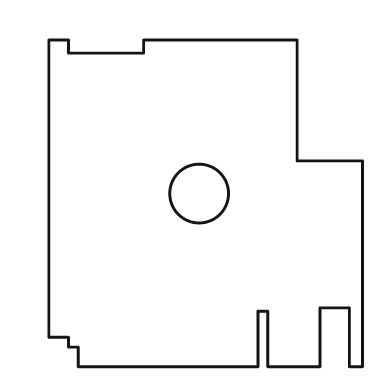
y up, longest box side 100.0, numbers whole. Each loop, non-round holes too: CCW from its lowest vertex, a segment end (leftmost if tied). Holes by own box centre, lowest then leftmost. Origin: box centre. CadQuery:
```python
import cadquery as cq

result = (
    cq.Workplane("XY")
    .moveTo(-39.0, -50.0)
    .lineTo(16.0, -50.0)
    .lineTo(16.0, -33.0)
    .lineTo(19.0, -33.0)
    .lineTo(19.0, -50.0)
    .lineTo(35.0, -50.0)
    .lineTo(35.0, -32.0)
    .lineTo(44.0, -32.0)
    .lineTo(44.0, -50.0)
    .lineTo(48.0, -50.0)
    .lineTo(48.0, 13.0)
    .lineTo(28.0, 13.0)
    .lineTo(28.0, 50.0)
    .lineTo(-19.0, 50.0)
    .lineTo(-19.0, 46.0)
    .lineTo(-42.0, 46.0)
    .lineTo(-42.0, 50.0)
    .lineTo(-48.0, 50.0)
    .lineTo(-48.0, -41.0)
    .lineTo(-42.0, -41.0)
    .lineTo(-42.0, -44.0)
    .lineTo(-39.0, -44.0)
    .close()
    .moveTo(-2.0, 3.0)
    .circle(9.0)
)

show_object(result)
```